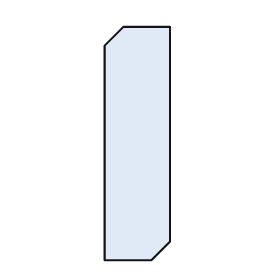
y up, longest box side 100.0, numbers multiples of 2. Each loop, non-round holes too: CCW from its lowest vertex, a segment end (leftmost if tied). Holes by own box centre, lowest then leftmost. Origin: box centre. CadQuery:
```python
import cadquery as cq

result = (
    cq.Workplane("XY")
    .moveTo(-14.0, -50.0)
    .lineTo(6.0, -50.0)
    .lineTo(14.0, -42.0)
    .lineTo(14.0, 50.0)
    .lineTo(-6.0, 50.0)
    .lineTo(-14.0, 42.0)
    .close()
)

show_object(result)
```